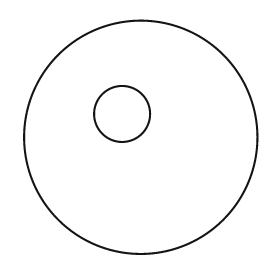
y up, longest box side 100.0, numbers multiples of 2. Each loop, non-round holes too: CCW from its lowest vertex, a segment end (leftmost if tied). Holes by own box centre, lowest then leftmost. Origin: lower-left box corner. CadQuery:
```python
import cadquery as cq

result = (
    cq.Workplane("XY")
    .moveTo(50.0, 50.0)
    .circle(50.0)
    .moveTo(42.0, 60.0)
    .circle(12.0)
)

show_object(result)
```